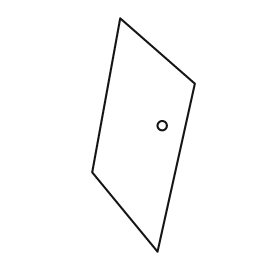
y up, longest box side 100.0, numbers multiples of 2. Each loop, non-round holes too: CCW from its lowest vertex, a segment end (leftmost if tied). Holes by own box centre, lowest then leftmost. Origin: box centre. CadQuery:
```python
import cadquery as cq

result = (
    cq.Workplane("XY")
    .moveTo(6.0, -50.0)
    .lineTo(22.0, 22.0)
    .lineTo(-10.0, 50.0)
    .lineTo(-22.0, -16.0)
    .close()
    .moveTo(8.0, 4.0)
    .circle(2.0)
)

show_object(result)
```